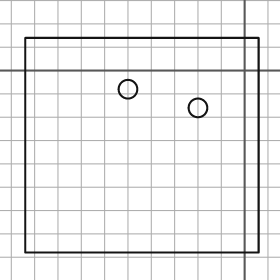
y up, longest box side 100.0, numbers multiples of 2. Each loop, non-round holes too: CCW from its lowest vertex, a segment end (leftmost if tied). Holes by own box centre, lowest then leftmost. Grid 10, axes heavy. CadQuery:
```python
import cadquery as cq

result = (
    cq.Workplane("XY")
    .moveTo(-94.0, -78.0)
    .lineTo(6.0, -78.0)
    .lineTo(6.0, 14.0)
    .lineTo(-94.0, 14.0)
    .close()
    .moveTo(-20.0, -16.0)
    .circle(4.0)
    .moveTo(-50.0, -8.0)
    .circle(4.0)
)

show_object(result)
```